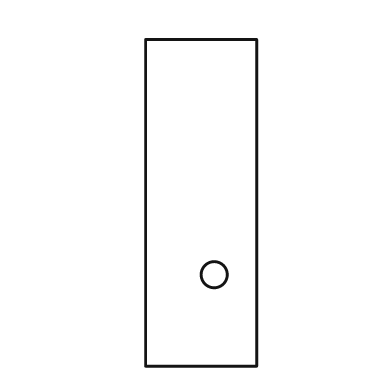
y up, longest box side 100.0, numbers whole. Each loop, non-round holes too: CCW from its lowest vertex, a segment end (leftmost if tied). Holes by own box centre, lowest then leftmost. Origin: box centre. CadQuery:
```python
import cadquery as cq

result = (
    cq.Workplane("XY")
    .moveTo(-17.0, -50.0)
    .lineTo(17.0, -50.0)
    .lineTo(17.0, 50.0)
    .lineTo(-17.0, 50.0)
    .close()
    .moveTo(4.0, -22.0)
    .circle(4.0)
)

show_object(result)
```